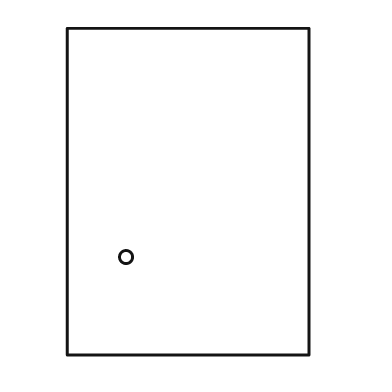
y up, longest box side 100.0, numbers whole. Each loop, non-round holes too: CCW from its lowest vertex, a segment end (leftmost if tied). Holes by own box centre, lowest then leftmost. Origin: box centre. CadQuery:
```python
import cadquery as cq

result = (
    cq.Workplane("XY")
    .moveTo(-37.0, -50.0)
    .lineTo(37.0, -50.0)
    .lineTo(37.0, 50.0)
    .lineTo(-37.0, 50.0)
    .close()
    .moveTo(-19.0, -20.0)
    .circle(2.0)
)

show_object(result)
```